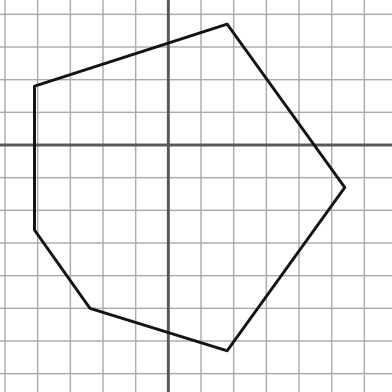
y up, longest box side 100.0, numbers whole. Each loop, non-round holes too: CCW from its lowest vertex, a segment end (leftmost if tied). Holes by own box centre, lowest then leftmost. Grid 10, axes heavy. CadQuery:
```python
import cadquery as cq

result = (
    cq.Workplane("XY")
    .moveTo(18.0, -63.0)
    .lineTo(54.0, -13.0)
    .lineTo(18.0, 37.0)
    .lineTo(-41.0, 18.0)
    .lineTo(-41.0, -26.0)
    .lineTo(-24.0, -50.0)
    .close()
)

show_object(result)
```